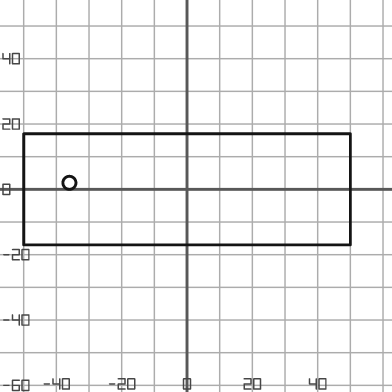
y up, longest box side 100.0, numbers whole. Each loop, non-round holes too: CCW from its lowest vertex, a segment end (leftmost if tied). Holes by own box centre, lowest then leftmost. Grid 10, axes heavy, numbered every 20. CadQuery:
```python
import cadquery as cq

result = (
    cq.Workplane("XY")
    .moveTo(-50.0, -17.0)
    .lineTo(50.0, -17.0)
    .lineTo(50.0, 17.0)
    .lineTo(-50.0, 17.0)
    .close()
    .moveTo(-36.0, 2.0)
    .circle(2.0)
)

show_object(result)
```